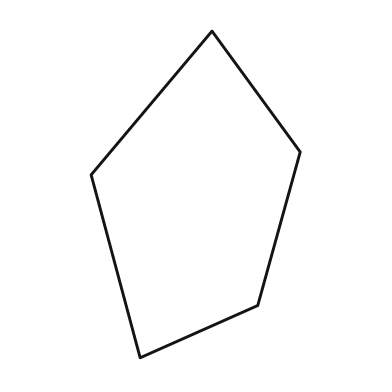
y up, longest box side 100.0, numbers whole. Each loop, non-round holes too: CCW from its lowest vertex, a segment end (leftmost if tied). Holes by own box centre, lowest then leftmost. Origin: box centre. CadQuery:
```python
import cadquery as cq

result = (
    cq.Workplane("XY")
    .moveTo(-17.0, -50.0)
    .lineTo(19.0, -34.0)
    .lineTo(32.0, 13.0)
    .lineTo(5.0, 50.0)
    .lineTo(-32.0, 6.0)
    .close()
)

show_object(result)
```